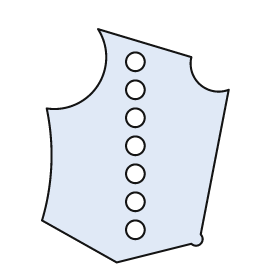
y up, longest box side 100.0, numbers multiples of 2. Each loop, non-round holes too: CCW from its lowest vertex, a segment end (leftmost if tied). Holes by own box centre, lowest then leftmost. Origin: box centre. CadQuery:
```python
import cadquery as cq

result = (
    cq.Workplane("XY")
    .moveTo(-8.0, -50.0)
    .lineTo(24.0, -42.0)
    .threePointArc((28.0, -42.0), (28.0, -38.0))
    .lineTo(40.0, 24.0)
    .threePointArc((28.0, 26.0), (24.0, 38.0))
    .lineTo(-16.0, 50.0)
    .threePointArc((-16.0, 26.0), (-38.0, 16.0))
    .threePointArc((-36.0, -8.0), (-40.0, -32.0))
    .close()
    .moveTo(0.0, -36.0)
    .circle(4.0)
    .moveTo(0.0, -24.0)
    .circle(4.0)
    .moveTo(0.0, -12.0)
    .circle(4.0)
    .moveTo(0.0, 0.0)
    .circle(4.0)
    .moveTo(0.0, 12.0)
    .circle(4.0)
    .moveTo(0.0, 24.0)
    .circle(4.0)
    .moveTo(0.0, 36.0)
    .circle(4.0)
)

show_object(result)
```